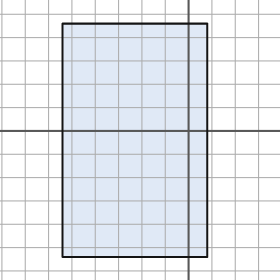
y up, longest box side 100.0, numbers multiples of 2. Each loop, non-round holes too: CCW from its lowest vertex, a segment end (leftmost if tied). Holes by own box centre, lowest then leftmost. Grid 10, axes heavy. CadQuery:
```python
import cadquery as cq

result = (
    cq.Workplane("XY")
    .moveTo(-54.0, -54.0)
    .lineTo(8.0, -54.0)
    .lineTo(8.0, 46.0)
    .lineTo(-54.0, 46.0)
    .close()
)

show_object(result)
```